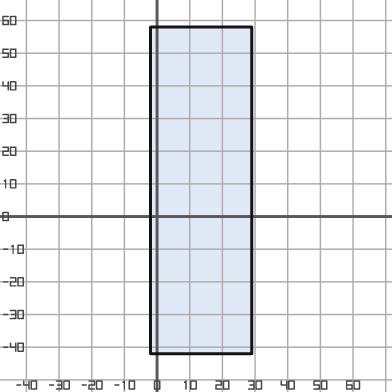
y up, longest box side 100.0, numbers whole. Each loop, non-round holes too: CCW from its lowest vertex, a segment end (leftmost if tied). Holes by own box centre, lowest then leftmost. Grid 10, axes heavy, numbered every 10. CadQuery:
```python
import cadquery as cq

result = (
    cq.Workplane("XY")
    .moveTo(-2.0, -42.0)
    .lineTo(29.0, -42.0)
    .lineTo(29.0, 58.0)
    .lineTo(-2.0, 58.0)
    .close()
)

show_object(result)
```